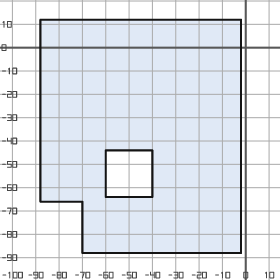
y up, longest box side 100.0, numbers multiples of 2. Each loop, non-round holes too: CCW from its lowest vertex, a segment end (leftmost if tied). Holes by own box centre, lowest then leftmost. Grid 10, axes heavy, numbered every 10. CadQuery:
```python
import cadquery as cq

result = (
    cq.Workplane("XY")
    .moveTo(-70.0, -88.0)
    .lineTo(-2.0, -88.0)
    .lineTo(-2.0, 12.0)
    .lineTo(-88.0, 12.0)
    .lineTo(-88.0, -66.0)
    .lineTo(-70.0, -66.0)
    .close()
    .moveTo(-60.0, -64.0)
    .lineTo(-40.0, -64.0)
    .lineTo(-40.0, -44.0)
    .lineTo(-60.0, -44.0)
    .close()
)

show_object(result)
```